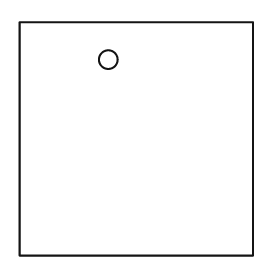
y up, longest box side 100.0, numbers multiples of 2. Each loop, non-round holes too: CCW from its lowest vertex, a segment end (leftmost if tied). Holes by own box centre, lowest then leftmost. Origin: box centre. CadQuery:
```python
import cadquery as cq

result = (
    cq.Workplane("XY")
    .moveTo(-50.0, -50.0)
    .lineTo(50.0, -50.0)
    .lineTo(50.0, 50.0)
    .lineTo(-50.0, 50.0)
    .close()
    .moveTo(-12.0, 34.0)
    .circle(4.0)
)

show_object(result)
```